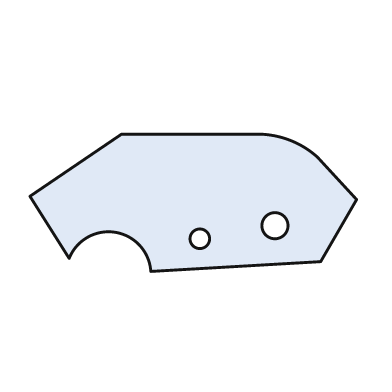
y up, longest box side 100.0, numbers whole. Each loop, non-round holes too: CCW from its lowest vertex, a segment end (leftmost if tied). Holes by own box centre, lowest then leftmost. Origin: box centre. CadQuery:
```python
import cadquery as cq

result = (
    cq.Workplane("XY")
    .moveTo(-13.0, -21.0)
    .lineTo(39.0, -18.0)
    .lineTo(50.0, 1.0)
    .lineTo(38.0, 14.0)
    .threePointArc((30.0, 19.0), (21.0, 21.0))
    .lineTo(-22.0, 21.0)
    .lineTo(-50.0, 2.0)
    .lineTo(-38.0, -17.0)
    .threePointArc((-24.0, -9.0), (-13.0, -21.0))
    .close()
    .moveTo(2.0, -11.0)
    .circle(3.0)
    .moveTo(25.0, -7.0)
    .circle(4.0)
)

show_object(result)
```